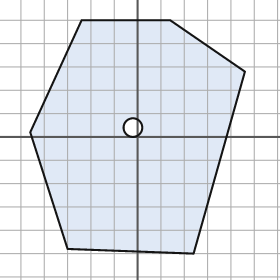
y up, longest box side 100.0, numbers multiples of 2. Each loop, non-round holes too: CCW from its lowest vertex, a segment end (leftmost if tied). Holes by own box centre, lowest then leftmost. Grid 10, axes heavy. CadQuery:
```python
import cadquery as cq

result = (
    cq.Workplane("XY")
    .moveTo(24.0, -50.0)
    .lineTo(46.0, 28.0)
    .lineTo(14.0, 50.0)
    .lineTo(-24.0, 50.0)
    .lineTo(-46.0, 2.0)
    .lineTo(-30.0, -48.0)
    .close()
    .moveTo(-2.0, 4.0)
    .circle(4.0)
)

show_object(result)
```